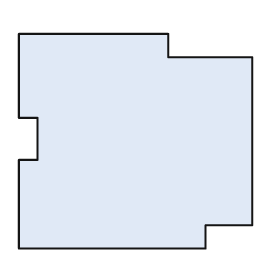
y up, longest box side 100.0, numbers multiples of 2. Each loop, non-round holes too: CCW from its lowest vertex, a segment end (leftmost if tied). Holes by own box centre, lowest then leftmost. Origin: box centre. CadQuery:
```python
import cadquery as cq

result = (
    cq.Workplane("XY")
    .moveTo(-50.0, -46.0)
    .lineTo(30.0, -46.0)
    .lineTo(30.0, -36.0)
    .lineTo(50.0, -36.0)
    .lineTo(50.0, 36.0)
    .lineTo(14.0, 36.0)
    .lineTo(14.0, 46.0)
    .lineTo(-50.0, 46.0)
    .lineTo(-50.0, 10.0)
    .lineTo(-42.0, 10.0)
    .lineTo(-42.0, -8.0)
    .lineTo(-50.0, -8.0)
    .close()
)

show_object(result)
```